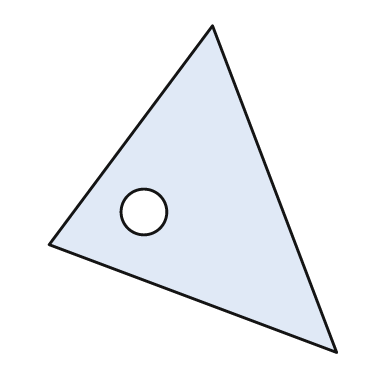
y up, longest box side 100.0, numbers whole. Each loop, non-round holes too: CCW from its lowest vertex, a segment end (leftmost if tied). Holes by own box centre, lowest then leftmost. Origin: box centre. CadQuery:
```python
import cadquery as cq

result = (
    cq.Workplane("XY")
    .moveTo(44.0, -50.0)
    .lineTo(6.0, 50.0)
    .lineTo(-44.0, -17.0)
    .close()
    .moveTo(-15.0, -7.0)
    .circle(7.0)
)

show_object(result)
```